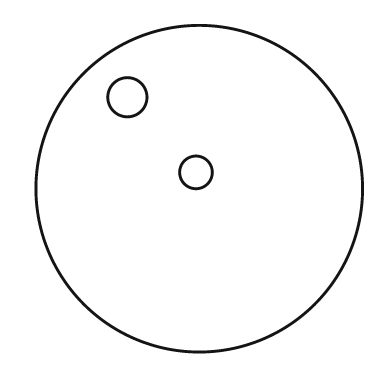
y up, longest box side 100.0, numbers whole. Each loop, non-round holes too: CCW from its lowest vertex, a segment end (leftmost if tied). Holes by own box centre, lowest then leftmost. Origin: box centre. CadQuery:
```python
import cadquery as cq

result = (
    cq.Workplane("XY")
    .moveTo(0.0, 0.0)
    .circle(50.0)
    .moveTo(-1.0, 5.0)
    .circle(5.0)
    .moveTo(-22.0, 28.0)
    .circle(6.0)
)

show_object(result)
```